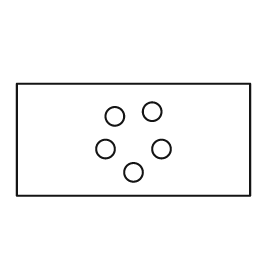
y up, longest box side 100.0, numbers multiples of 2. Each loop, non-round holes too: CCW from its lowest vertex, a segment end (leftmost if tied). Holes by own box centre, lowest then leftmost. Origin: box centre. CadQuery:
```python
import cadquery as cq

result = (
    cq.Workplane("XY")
    .moveTo(-50.0, -24.0)
    .lineTo(50.0, -24.0)
    .lineTo(50.0, 24.0)
    .lineTo(-50.0, 24.0)
    .close()
    .moveTo(0.0, -14.0)
    .circle(4.0)
    .moveTo(-12.0, -4.0)
    .circle(4.0)
    .moveTo(12.0, -4.0)
    .circle(4.0)
    .moveTo(-8.0, 10.0)
    .circle(4.0)
    .moveTo(8.0, 12.0)
    .circle(4.0)
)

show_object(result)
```